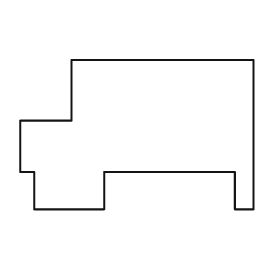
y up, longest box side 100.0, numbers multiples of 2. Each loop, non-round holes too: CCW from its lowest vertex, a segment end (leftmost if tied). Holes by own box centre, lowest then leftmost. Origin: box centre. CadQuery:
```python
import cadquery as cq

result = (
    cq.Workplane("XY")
    .moveTo(-44.0, -32.0)
    .lineTo(-14.0, -32.0)
    .lineTo(-14.0, -16.0)
    .lineTo(42.0, -16.0)
    .lineTo(42.0, -32.0)
    .lineTo(50.0, -32.0)
    .lineTo(50.0, 32.0)
    .lineTo(-28.0, 32.0)
    .lineTo(-28.0, 6.0)
    .lineTo(-50.0, 6.0)
    .lineTo(-50.0, -16.0)
    .lineTo(-44.0, -16.0)
    .close()
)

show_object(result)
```